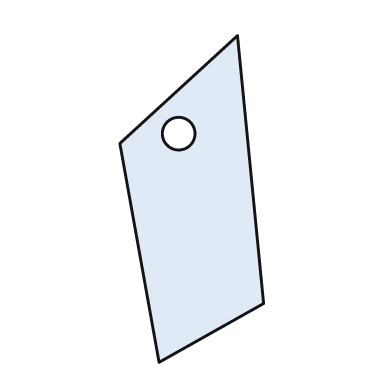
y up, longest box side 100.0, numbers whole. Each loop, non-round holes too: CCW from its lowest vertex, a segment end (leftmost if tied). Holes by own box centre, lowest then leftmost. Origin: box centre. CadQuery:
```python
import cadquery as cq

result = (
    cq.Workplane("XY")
    .moveTo(-10.0, -50.0)
    .lineTo(22.0, -32.0)
    .lineTo(14.0, 50.0)
    .lineTo(-22.0, 17.0)
    .close()
    .moveTo(-4.0, 20.0)
    .circle(5.0)
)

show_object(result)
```